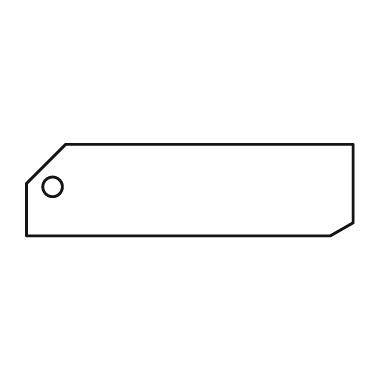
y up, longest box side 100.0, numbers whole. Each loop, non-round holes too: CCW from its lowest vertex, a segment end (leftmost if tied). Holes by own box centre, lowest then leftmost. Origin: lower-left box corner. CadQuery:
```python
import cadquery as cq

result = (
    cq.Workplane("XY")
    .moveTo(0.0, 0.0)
    .lineTo(93.0, 0.0)
    .lineTo(100.0, 4.0)
    .lineTo(100.0, 28.0)
    .lineTo(12.0, 28.0)
    .lineTo(0.0, 16.0)
    .close()
    .moveTo(8.0, 15.0)
    .circle(3.0)
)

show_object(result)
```